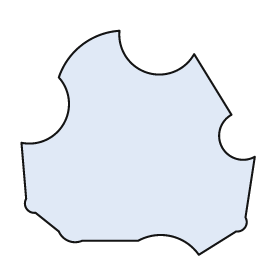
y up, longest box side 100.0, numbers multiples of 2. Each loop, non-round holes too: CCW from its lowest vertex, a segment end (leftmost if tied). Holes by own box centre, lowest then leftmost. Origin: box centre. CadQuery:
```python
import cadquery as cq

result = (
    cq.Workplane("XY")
    .moveTo(26.0, -48.0)
    .lineTo(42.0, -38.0)
    .threePointArc((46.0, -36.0), (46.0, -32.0))
    .lineTo(50.0, -6.0)
    .threePointArc((36.0, -2.0), (40.0, 12.0))
    .lineTo(24.0, 38.0)
    .threePointArc((4.0, 30.0), (-8.0, 48.0))
    .threePointArc((-24.0, 42.0), (-34.0, 28.0))
    .threePointArc((-32.0, 8.0), (-50.0, 0.0))
    .lineTo(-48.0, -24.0)
    .threePointArc((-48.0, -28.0), (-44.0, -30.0))
    .lineTo(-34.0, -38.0)
    .threePointArc((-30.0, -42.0), (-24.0, -42.0))
    .lineTo(0.0, -42.0)
    .threePointArc((14.0, -40.0), (26.0, -48.0))
    .close()
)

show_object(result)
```